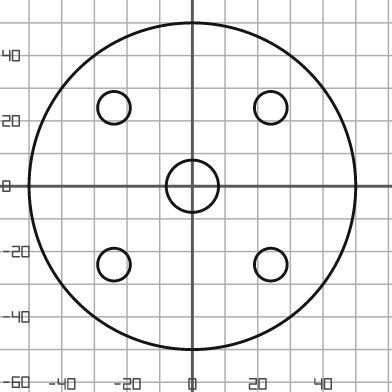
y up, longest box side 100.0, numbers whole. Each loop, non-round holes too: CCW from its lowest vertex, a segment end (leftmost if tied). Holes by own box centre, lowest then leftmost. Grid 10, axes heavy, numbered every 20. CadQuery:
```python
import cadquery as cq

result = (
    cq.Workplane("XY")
    .moveTo(0.0, 0.0)
    .circle(50.0)
    .moveTo(-24.0, -24.0)
    .circle(5.0)
    .moveTo(24.0, -24.0)
    .circle(5.0)
    .moveTo(0.0, 0.0)
    .circle(8.0)
    .moveTo(-24.0, 24.0)
    .circle(5.0)
    .moveTo(24.0, 24.0)
    .circle(5.0)
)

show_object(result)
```